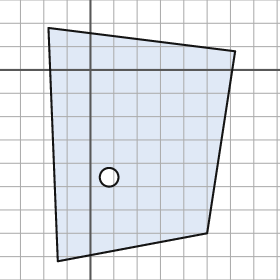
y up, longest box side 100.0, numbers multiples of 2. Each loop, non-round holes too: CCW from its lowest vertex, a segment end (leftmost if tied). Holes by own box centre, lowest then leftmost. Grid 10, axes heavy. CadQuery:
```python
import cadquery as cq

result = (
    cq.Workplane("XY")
    .moveTo(-14.0, -82.0)
    .lineTo(50.0, -70.0)
    .lineTo(62.0, 8.0)
    .lineTo(-18.0, 18.0)
    .close()
    .moveTo(8.0, -46.0)
    .circle(4.0)
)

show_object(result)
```